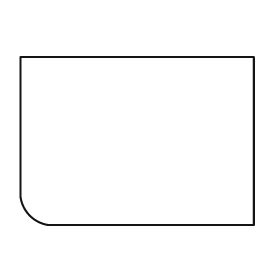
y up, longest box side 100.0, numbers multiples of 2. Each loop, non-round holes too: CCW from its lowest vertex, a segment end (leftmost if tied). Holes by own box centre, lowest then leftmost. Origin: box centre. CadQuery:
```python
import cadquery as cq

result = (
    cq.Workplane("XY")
    .moveTo(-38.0, -36.0)
    .lineTo(50.0, -36.0)
    .lineTo(50.0, 36.0)
    .lineTo(-50.0, 36.0)
    .lineTo(-50.0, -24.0)
    .threePointArc((-46.0, -32.0), (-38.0, -36.0))
    .close()
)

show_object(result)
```